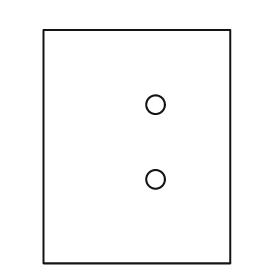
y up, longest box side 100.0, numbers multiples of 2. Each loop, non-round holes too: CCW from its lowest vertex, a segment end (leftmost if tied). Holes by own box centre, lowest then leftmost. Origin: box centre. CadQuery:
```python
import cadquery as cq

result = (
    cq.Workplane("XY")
    .moveTo(-40.0, -50.0)
    .lineTo(40.0, -50.0)
    .lineTo(40.0, 50.0)
    .lineTo(-40.0, 50.0)
    .close()
    .moveTo(8.0, -14.0)
    .circle(4.0)
    .moveTo(8.0, 18.0)
    .circle(4.0)
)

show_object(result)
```